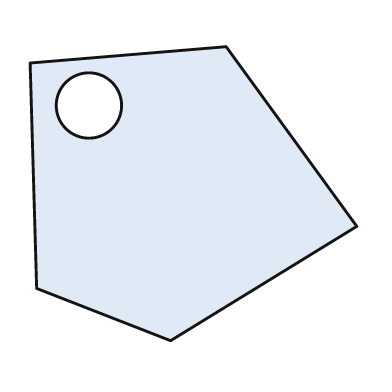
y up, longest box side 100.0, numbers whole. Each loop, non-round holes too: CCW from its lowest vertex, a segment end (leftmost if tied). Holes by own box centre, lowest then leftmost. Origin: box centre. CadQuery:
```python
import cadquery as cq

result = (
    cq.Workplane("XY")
    .moveTo(-7.0, -45.0)
    .lineTo(50.0, -10.0)
    .lineTo(10.0, 45.0)
    .lineTo(-50.0, 40.0)
    .lineTo(-48.0, -29.0)
    .close()
    .moveTo(-32.0, 27.0)
    .circle(10.0)
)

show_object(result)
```